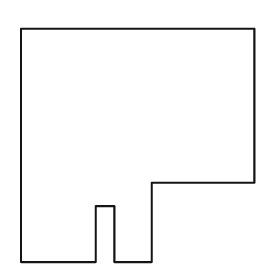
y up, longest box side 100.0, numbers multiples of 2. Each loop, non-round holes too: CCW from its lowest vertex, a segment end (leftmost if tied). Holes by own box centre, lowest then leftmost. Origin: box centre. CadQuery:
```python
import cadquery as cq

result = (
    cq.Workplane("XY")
    .moveTo(-50.0, -50.0)
    .lineTo(-18.0, -50.0)
    .lineTo(-18.0, -26.0)
    .lineTo(-10.0, -26.0)
    .lineTo(-10.0, -50.0)
    .lineTo(6.0, -50.0)
    .lineTo(6.0, -16.0)
    .lineTo(50.0, -16.0)
    .lineTo(50.0, 50.0)
    .lineTo(-50.0, 50.0)
    .close()
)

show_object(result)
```